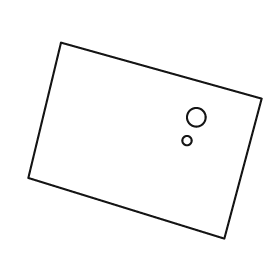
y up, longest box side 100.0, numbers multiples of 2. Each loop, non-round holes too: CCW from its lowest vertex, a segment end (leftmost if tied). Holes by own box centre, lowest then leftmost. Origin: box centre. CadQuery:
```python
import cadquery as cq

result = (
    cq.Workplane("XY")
    .moveTo(34.0, -42.0)
    .lineTo(50.0, 18.0)
    .lineTo(-36.0, 42.0)
    .lineTo(-50.0, -16.0)
    .close()
    .moveTo(18.0, 0.0)
    .circle(2.0)
    .moveTo(22.0, 10.0)
    .circle(4.0)
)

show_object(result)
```